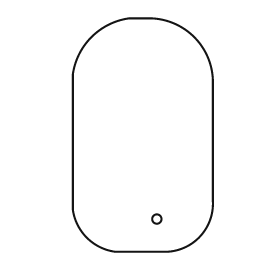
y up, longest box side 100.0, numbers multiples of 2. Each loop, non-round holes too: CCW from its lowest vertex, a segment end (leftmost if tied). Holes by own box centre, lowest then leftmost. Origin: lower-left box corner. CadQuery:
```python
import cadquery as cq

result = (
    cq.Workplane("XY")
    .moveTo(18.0, 0.0)
    .lineTo(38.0, 0.0)
    .threePointArc((54.0, 6.0), (60.0, 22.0))
    .lineTo(60.0, 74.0)
    .threePointArc((52.0, 92.0), (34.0, 100.0))
    .lineTo(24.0, 100.0)
    .threePointArc((8.0, 92.0), (0.0, 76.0))
    .lineTo(0.0, 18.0)
    .threePointArc((6.0, 6.0), (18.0, 0.0))
    .close()
    .moveTo(36.0, 14.0)
    .circle(2.0)
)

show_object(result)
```